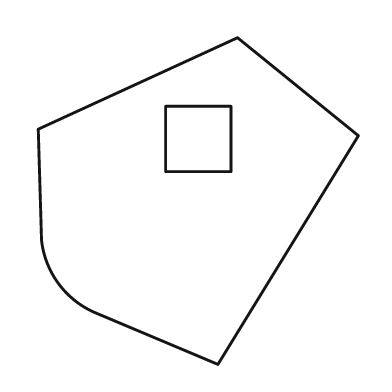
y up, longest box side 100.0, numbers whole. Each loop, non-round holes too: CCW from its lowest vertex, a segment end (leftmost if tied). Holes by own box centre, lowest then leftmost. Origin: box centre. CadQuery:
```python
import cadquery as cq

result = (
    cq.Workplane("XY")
    .moveTo(6.0, -50.0)
    .lineTo(49.0, 20.0)
    .lineTo(12.0, 50.0)
    .lineTo(-49.0, 22.0)
    .lineTo(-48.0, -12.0)
    .threePointArc((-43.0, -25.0), (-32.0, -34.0))
    .close()
    .moveTo(-10.0, 9.0)
    .lineTo(10.0, 9.0)
    .lineTo(10.0, 29.0)
    .lineTo(-10.0, 29.0)
    .close()
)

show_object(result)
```